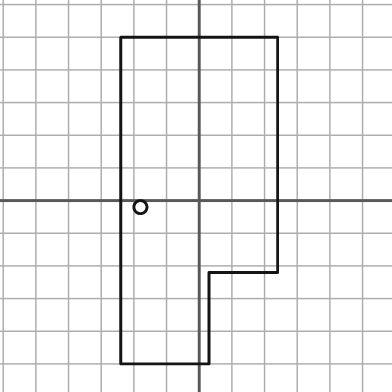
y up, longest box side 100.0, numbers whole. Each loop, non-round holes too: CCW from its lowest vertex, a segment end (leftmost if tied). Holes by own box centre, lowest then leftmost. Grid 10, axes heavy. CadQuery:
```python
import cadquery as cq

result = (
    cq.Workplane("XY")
    .moveTo(-24.0, -50.0)
    .lineTo(3.0, -50.0)
    .lineTo(3.0, -22.0)
    .lineTo(24.0, -22.0)
    .lineTo(24.0, 50.0)
    .lineTo(-24.0, 50.0)
    .close()
    .moveTo(-18.0, -2.0)
    .circle(2.0)
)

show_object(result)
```